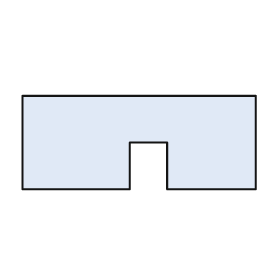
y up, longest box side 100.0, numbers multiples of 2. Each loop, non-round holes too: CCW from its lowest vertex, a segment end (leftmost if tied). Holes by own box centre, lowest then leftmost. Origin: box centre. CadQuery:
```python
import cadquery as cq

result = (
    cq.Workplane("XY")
    .moveTo(-50.0, -20.0)
    .lineTo(-4.0, -20.0)
    .lineTo(-4.0, 0.0)
    .lineTo(12.0, 0.0)
    .lineTo(12.0, -20.0)
    .lineTo(50.0, -20.0)
    .lineTo(50.0, 20.0)
    .lineTo(-50.0, 20.0)
    .close()
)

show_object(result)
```